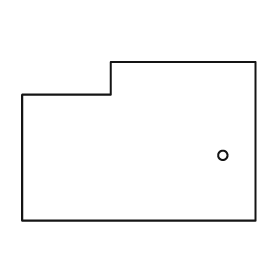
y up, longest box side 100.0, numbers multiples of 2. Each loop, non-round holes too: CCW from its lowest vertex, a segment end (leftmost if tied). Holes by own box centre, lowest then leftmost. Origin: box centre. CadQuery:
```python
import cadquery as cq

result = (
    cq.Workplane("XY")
    .moveTo(-50.0, -34.0)
    .lineTo(50.0, -34.0)
    .lineTo(50.0, 34.0)
    .lineTo(-12.0, 34.0)
    .lineTo(-12.0, 20.0)
    .lineTo(-50.0, 20.0)
    .close()
    .moveTo(36.0, -6.0)
    .circle(2.0)
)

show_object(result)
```